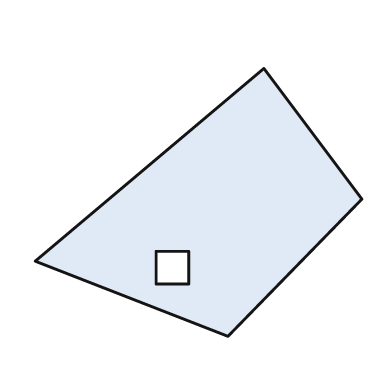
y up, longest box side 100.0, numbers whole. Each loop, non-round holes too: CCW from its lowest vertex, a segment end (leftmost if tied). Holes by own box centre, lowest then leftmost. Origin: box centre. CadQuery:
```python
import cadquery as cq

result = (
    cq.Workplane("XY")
    .moveTo(9.0, -41.0)
    .lineTo(50.0, 1.0)
    .lineTo(20.0, 41.0)
    .lineTo(-50.0, -18.0)
    .close()
    .moveTo(-13.0, -25.0)
    .lineTo(-3.0, -25.0)
    .lineTo(-3.0, -15.0)
    .lineTo(-13.0, -15.0)
    .close()
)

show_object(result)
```